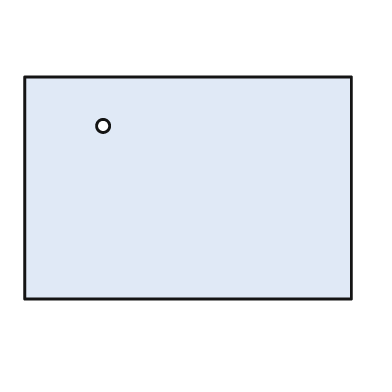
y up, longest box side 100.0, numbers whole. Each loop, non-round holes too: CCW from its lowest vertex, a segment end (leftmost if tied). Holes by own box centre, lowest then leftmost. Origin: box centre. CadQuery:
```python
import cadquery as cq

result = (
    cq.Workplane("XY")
    .moveTo(-50.0, -34.0)
    .lineTo(50.0, -34.0)
    .lineTo(50.0, 34.0)
    .lineTo(-50.0, 34.0)
    .close()
    .moveTo(-26.0, 19.0)
    .circle(2.0)
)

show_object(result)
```